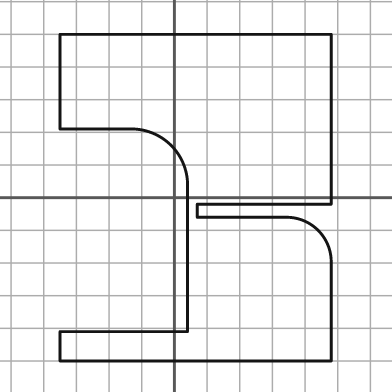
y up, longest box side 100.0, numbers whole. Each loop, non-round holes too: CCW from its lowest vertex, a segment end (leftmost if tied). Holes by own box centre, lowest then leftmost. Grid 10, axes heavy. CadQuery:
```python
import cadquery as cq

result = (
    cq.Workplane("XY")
    .moveTo(-35.0, -50.0)
    .lineTo(48.0, -50.0)
    .lineTo(48.0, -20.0)
    .threePointArc((44.0, -10.0), (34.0, -6.0))
    .lineTo(7.0, -6.0)
    .lineTo(7.0, -2.0)
    .lineTo(48.0, -2.0)
    .lineTo(48.0, 50.0)
    .lineTo(-35.0, 50.0)
    .lineTo(-35.0, 21.0)
    .lineTo(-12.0, 21.0)
    .threePointArc((-1.0, 16.0), (4.0, 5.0))
    .lineTo(4.0, -41.0)
    .lineTo(-35.0, -41.0)
    .close()
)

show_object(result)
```